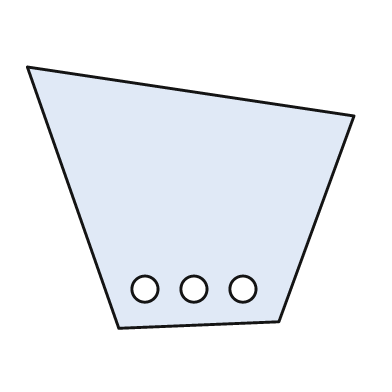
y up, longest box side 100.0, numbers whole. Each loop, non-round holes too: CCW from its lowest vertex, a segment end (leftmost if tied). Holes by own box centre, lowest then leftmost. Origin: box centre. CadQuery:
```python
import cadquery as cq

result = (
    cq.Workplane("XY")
    .moveTo(-22.0, -40.0)
    .lineTo(27.0, -38.0)
    .lineTo(50.0, 25.0)
    .lineTo(-50.0, 40.0)
    .close()
    .moveTo(-14.0, -28.0)
    .circle(4.0)
    .moveTo(1.0, -28.0)
    .circle(4.0)
    .moveTo(16.0, -28.0)
    .circle(4.0)
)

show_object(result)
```